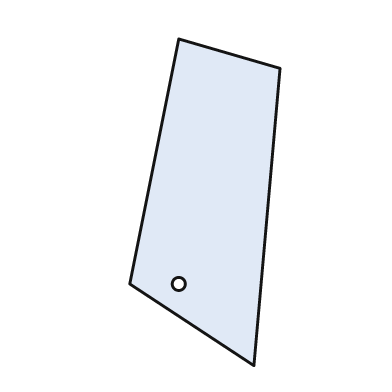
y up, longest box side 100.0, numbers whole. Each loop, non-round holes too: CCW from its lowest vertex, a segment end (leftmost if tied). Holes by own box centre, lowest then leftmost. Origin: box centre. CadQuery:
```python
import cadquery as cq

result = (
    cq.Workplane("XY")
    .moveTo(15.0, -50.0)
    .lineTo(23.0, 41.0)
    .lineTo(-8.0, 50.0)
    .lineTo(-23.0, -25.0)
    .close()
    .moveTo(-8.0, -25.0)
    .circle(2.0)
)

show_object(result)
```